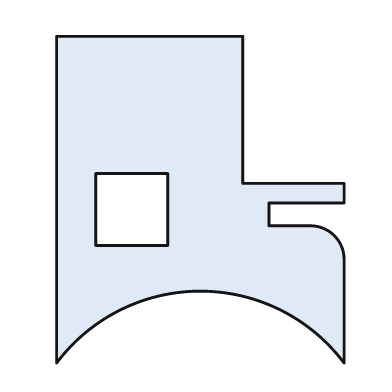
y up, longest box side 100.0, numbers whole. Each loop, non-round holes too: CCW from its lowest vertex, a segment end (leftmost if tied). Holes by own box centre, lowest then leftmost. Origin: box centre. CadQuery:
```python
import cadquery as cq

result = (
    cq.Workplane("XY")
    .moveTo(-44.0, -50.0)
    .threePointArc((0.0, -28.0), (44.0, -50.0))
    .lineTo(44.0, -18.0)
    .threePointArc((41.0, -11.0), (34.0, -8.0))
    .lineTo(21.0, -8.0)
    .lineTo(21.0, -1.0)
    .lineTo(44.0, -1.0)
    .lineTo(44.0, 5.0)
    .lineTo(13.0, 5.0)
    .lineTo(13.0, 50.0)
    .lineTo(-44.0, 50.0)
    .close()
    .moveTo(-32.0, -14.0)
    .lineTo(-10.0, -14.0)
    .lineTo(-10.0, 8.0)
    .lineTo(-32.0, 8.0)
    .close()
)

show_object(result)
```